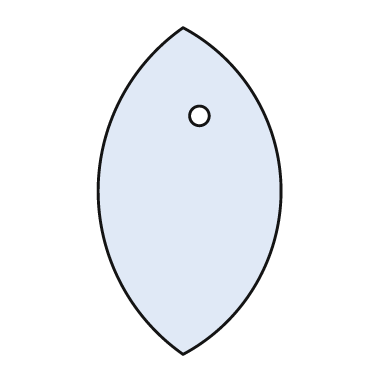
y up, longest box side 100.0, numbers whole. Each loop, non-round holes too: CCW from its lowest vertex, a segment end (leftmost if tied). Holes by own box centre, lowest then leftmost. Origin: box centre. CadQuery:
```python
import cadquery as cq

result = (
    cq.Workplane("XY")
    .moveTo(-2.0, -50.0)
    .threePointArc((28.0, 0.0), (-2.0, 50.0))
    .threePointArc((-28.0, 0.0), (-2.0, -50.0))
    .close()
    .moveTo(3.0, 23.0)
    .circle(3.0)
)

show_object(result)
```